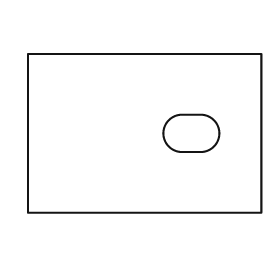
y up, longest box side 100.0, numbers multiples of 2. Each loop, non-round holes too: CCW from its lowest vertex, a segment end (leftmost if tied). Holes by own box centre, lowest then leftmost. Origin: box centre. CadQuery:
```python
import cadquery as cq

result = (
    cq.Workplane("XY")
    .moveTo(-50.0, -34.0)
    .lineTo(50.0, -34.0)
    .lineTo(50.0, 34.0)
    .lineTo(-50.0, 34.0)
    .close()
    .moveTo(16.0, -8.0)
    .lineTo(24.0, -8.0)
    .threePointArc((32.0, 0.0), (24.0, 8.0))
    .lineTo(16.0, 8.0)
    .threePointArc((8.0, 0.0), (16.0, -8.0))
    .close()
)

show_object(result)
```